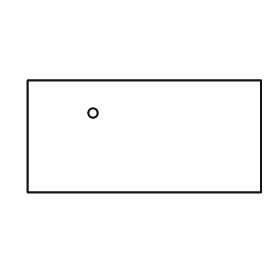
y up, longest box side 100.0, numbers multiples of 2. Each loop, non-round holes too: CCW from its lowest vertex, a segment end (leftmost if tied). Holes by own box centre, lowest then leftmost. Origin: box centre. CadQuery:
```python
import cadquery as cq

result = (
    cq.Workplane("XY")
    .moveTo(-50.0, -24.0)
    .lineTo(50.0, -24.0)
    .lineTo(50.0, 24.0)
    .lineTo(-50.0, 24.0)
    .close()
    .moveTo(-22.0, 10.0)
    .circle(2.0)
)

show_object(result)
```